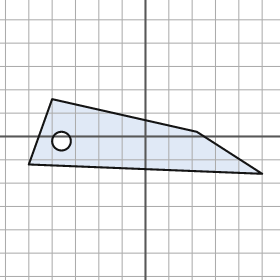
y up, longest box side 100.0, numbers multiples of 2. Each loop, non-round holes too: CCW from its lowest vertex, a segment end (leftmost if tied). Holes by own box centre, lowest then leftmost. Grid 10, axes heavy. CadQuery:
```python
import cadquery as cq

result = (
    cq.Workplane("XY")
    .moveTo(50.0, -16.0)
    .lineTo(22.0, 2.0)
    .lineTo(-40.0, 16.0)
    .lineTo(-50.0, -12.0)
    .close()
    .moveTo(-36.0, -2.0)
    .circle(4.0)
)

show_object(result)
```